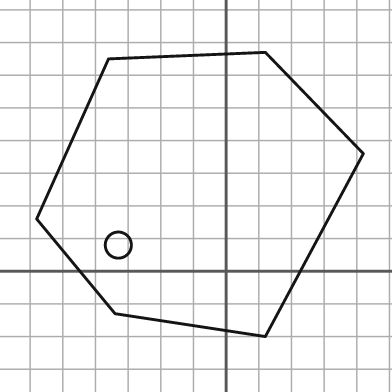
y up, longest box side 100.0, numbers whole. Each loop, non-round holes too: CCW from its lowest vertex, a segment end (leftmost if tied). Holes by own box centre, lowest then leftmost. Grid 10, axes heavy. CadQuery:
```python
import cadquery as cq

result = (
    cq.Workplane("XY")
    .moveTo(12.0, -20.0)
    .lineTo(42.0, 36.0)
    .lineTo(12.0, 67.0)
    .lineTo(-36.0, 65.0)
    .lineTo(-58.0, 16.0)
    .lineTo(-34.0, -13.0)
    .close()
    .moveTo(-33.0, 8.0)
    .circle(4.0)
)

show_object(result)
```